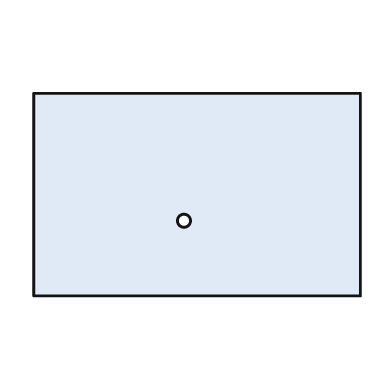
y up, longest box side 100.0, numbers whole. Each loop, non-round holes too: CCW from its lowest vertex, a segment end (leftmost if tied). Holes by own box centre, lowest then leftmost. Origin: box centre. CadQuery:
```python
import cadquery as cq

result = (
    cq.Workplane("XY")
    .moveTo(-50.0, -31.0)
    .lineTo(50.0, -31.0)
    .lineTo(50.0, 31.0)
    .lineTo(-50.0, 31.0)
    .close()
    .moveTo(-4.0, -8.0)
    .circle(2.0)
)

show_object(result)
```